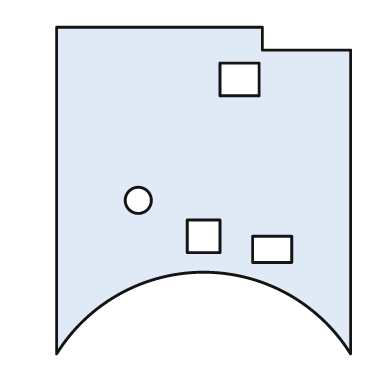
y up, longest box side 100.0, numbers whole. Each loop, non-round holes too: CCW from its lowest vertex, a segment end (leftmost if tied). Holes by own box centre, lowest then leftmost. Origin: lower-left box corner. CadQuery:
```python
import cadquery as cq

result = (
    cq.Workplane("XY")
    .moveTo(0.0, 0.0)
    .threePointArc((45.0, 25.0), (90.0, 0.0))
    .lineTo(90.0, 93.0)
    .lineTo(63.0, 93.0)
    .lineTo(63.0, 100.0)
    .lineTo(0.0, 100.0)
    .close()
    .moveTo(60.0, 28.0)
    .lineTo(72.0, 28.0)
    .lineTo(72.0, 36.0)
    .lineTo(60.0, 36.0)
    .close()
    .moveTo(40.0, 31.0)
    .lineTo(50.0, 31.0)
    .lineTo(50.0, 41.0)
    .lineTo(40.0, 41.0)
    .close()
    .moveTo(25.0, 47.0)
    .circle(4.0)
    .moveTo(50.0, 79.0)
    .lineTo(62.0, 79.0)
    .lineTo(62.0, 89.0)
    .lineTo(50.0, 89.0)
    .close()
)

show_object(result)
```